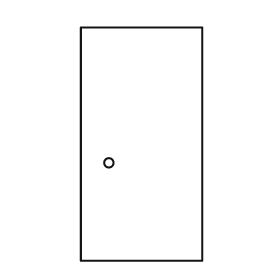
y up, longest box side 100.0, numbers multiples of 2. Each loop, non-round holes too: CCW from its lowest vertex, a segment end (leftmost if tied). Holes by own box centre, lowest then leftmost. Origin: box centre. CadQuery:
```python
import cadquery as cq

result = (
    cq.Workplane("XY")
    .moveTo(-26.0, -50.0)
    .lineTo(26.0, -50.0)
    .lineTo(26.0, 50.0)
    .lineTo(-26.0, 50.0)
    .close()
    .moveTo(-14.0, -8.0)
    .circle(2.0)
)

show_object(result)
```